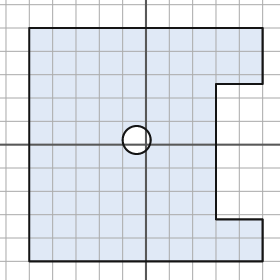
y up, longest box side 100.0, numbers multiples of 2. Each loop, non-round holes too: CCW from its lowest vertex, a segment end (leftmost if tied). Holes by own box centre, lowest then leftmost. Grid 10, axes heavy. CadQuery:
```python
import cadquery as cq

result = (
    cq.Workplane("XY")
    .moveTo(-50.0, -50.0)
    .lineTo(50.0, -50.0)
    .lineTo(50.0, -32.0)
    .lineTo(30.0, -32.0)
    .lineTo(30.0, 26.0)
    .lineTo(50.0, 26.0)
    .lineTo(50.0, 50.0)
    .lineTo(-50.0, 50.0)
    .close()
    .moveTo(-4.0, 2.0)
    .circle(6.0)
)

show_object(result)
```